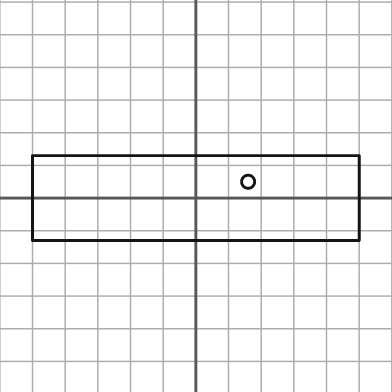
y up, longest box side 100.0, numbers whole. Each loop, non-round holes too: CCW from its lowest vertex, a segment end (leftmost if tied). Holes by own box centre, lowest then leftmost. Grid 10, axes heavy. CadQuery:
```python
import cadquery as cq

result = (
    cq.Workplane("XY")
    .moveTo(-50.0, -13.0)
    .lineTo(50.0, -13.0)
    .lineTo(50.0, 13.0)
    .lineTo(-50.0, 13.0)
    .close()
    .moveTo(16.0, 5.0)
    .circle(2.0)
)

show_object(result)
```